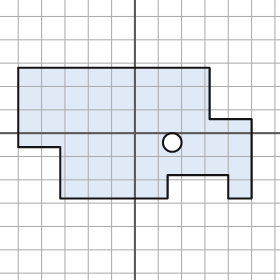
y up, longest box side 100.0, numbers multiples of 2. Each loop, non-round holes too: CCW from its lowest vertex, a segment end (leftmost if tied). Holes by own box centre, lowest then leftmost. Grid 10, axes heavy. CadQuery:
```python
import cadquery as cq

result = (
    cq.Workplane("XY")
    .moveTo(-32.0, -28.0)
    .lineTo(14.0, -28.0)
    .lineTo(14.0, -18.0)
    .lineTo(40.0, -18.0)
    .lineTo(40.0, -28.0)
    .lineTo(50.0, -28.0)
    .lineTo(50.0, 6.0)
    .lineTo(32.0, 6.0)
    .lineTo(32.0, 28.0)
    .lineTo(-50.0, 28.0)
    .lineTo(-50.0, -6.0)
    .lineTo(-32.0, -6.0)
    .close()
    .moveTo(16.0, -4.0)
    .circle(4.0)
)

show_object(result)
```